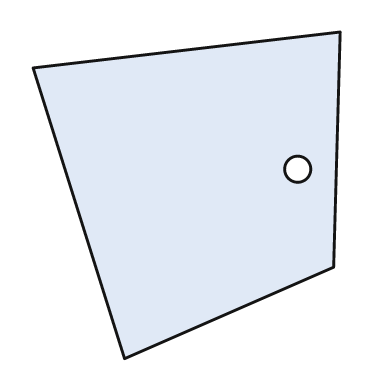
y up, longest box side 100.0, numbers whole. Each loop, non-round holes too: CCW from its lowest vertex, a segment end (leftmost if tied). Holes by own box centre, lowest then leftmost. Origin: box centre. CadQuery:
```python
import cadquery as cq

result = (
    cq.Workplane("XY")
    .moveTo(-19.0, -50.0)
    .lineTo(45.0, -22.0)
    .lineTo(47.0, 50.0)
    .lineTo(-47.0, 39.0)
    .close()
    .moveTo(34.0, 8.0)
    .circle(4.0)
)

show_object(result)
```